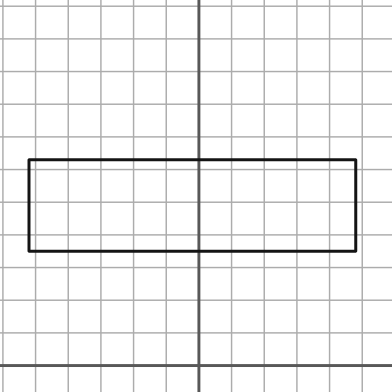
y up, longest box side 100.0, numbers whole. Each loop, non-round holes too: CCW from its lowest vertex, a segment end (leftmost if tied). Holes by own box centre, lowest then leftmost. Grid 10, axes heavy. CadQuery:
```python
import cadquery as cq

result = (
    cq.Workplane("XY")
    .moveTo(-52.0, 35.0)
    .lineTo(48.0, 35.0)
    .lineTo(48.0, 63.0)
    .lineTo(-52.0, 63.0)
    .close()
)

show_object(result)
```